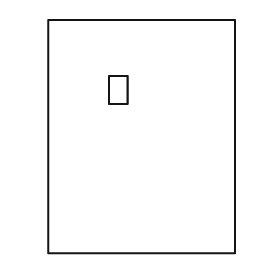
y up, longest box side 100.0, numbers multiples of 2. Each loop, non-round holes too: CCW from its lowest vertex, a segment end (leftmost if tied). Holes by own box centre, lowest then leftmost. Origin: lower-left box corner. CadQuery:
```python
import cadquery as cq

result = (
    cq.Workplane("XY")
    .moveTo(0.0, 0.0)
    .lineTo(80.0, 0.0)
    .lineTo(80.0, 100.0)
    .lineTo(0.0, 100.0)
    .close()
    .moveTo(26.0, 64.0)
    .lineTo(34.0, 64.0)
    .lineTo(34.0, 76.0)
    .lineTo(26.0, 76.0)
    .close()
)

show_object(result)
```